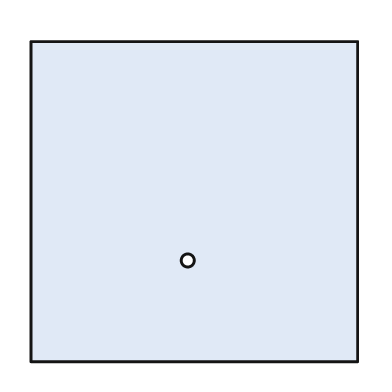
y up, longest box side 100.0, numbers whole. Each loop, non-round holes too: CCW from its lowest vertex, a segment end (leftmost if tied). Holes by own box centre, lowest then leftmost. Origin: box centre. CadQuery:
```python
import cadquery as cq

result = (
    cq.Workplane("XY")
    .moveTo(-50.0, -49.0)
    .lineTo(50.0, -49.0)
    .lineTo(50.0, 49.0)
    .lineTo(-50.0, 49.0)
    .close()
    .moveTo(-2.0, -18.0)
    .circle(2.0)
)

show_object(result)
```